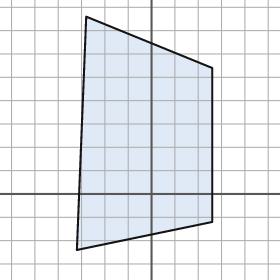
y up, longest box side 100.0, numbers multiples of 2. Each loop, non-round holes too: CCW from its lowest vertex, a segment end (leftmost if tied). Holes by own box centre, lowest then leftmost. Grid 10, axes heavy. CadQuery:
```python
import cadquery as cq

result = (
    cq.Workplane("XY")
    .moveTo(-32.0, -24.0)
    .lineTo(26.0, -12.0)
    .lineTo(26.0, 54.0)
    .lineTo(-28.0, 76.0)
    .close()
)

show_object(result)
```